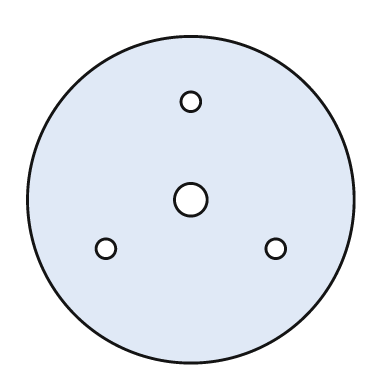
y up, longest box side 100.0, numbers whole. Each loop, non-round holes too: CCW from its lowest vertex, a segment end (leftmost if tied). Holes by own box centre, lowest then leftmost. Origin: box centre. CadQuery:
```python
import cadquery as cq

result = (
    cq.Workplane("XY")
    .moveTo(0.0, 0.0)
    .circle(50.0)
    .moveTo(-26.0, -15.0)
    .circle(3.0)
    .moveTo(26.0, -15.0)
    .circle(3.0)
    .moveTo(0.0, 0.0)
    .circle(5.0)
    .moveTo(0.0, 30.0)
    .circle(3.0)
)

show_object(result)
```